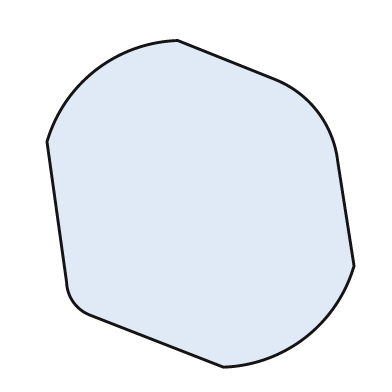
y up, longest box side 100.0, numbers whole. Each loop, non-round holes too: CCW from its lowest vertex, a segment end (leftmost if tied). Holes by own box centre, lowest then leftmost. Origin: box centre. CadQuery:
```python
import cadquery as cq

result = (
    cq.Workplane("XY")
    .moveTo(7.0, -50.0)
    .threePointArc((32.0, -41.0), (47.0, -19.0))
    .lineTo(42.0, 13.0)
    .threePointArc((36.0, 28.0), (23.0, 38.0))
    .lineTo(-7.0, 50.0)
    .threePointArc((-32.0, 41.0), (-47.0, 19.0))
    .lineTo(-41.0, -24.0)
    .threePointArc((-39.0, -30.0), (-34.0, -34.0))
    .close()
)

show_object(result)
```